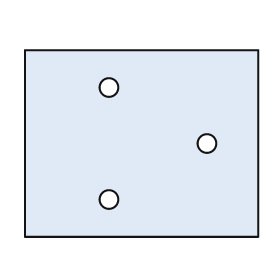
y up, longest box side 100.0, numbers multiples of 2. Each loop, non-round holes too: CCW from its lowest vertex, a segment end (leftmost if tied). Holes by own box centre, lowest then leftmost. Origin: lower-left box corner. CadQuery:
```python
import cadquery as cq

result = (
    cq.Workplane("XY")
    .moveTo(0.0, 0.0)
    .lineTo(100.0, 0.0)
    .lineTo(100.0, 80.0)
    .lineTo(0.0, 80.0)
    .close()
    .moveTo(36.0, 16.0)
    .circle(4.0)
    .moveTo(78.0, 40.0)
    .circle(4.0)
    .moveTo(36.0, 64.0)
    .circle(4.0)
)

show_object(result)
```